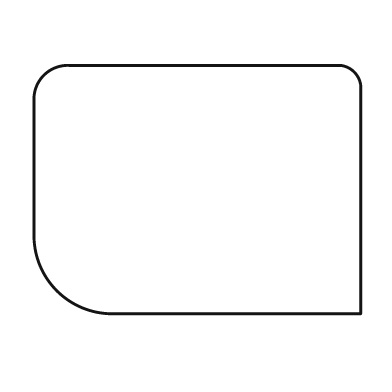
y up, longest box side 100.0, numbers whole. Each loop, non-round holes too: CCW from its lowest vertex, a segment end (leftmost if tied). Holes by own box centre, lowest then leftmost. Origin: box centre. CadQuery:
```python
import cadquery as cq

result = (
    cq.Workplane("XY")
    .moveTo(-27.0, -38.0)
    .lineTo(50.0, -38.0)
    .lineTo(50.0, 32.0)
    .threePointArc((48.0, 36.0), (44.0, 38.0))
    .lineTo(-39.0, 38.0)
    .threePointArc((-47.0, 35.0), (-50.0, 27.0))
    .lineTo(-50.0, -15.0)
    .threePointArc((-43.0, -31.0), (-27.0, -38.0))
    .close()
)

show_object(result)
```